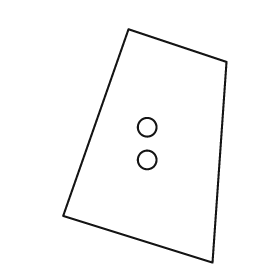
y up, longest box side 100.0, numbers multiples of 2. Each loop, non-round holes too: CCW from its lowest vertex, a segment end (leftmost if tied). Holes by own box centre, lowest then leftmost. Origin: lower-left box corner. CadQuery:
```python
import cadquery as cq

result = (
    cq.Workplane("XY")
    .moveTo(64.0, 0.0)
    .lineTo(70.0, 86.0)
    .lineTo(28.0, 100.0)
    .lineTo(0.0, 20.0)
    .close()
    .moveTo(36.0, 44.0)
    .circle(4.0)
    .moveTo(36.0, 58.0)
    .circle(4.0)
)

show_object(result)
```